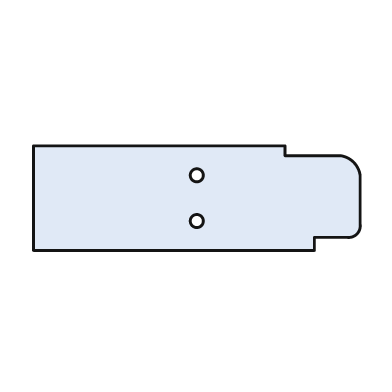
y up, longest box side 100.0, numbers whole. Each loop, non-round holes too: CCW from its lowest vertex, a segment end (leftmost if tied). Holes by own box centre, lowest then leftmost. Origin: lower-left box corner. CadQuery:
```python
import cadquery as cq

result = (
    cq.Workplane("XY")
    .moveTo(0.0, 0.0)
    .lineTo(86.0, 0.0)
    .lineTo(86.0, 4.0)
    .lineTo(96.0, 4.0)
    .threePointArc((99.0, 5.0), (100.0, 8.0))
    .lineTo(100.0, 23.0)
    .threePointArc((98.0, 27.0), (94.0, 29.0))
    .lineTo(77.0, 29.0)
    .lineTo(77.0, 32.0)
    .lineTo(0.0, 32.0)
    .close()
    .moveTo(50.0, 9.0)
    .circle(2.0)
    .moveTo(50.0, 23.0)
    .circle(2.0)
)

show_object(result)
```